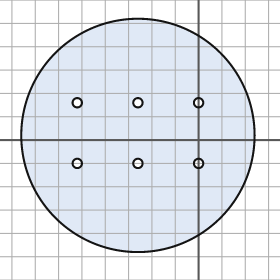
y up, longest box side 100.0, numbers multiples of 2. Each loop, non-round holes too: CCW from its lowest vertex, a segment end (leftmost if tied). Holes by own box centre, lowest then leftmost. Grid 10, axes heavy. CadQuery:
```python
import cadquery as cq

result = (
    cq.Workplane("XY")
    .moveTo(-26.0, 2.0)
    .circle(50.0)
    .moveTo(-52.0, -10.0)
    .circle(2.0)
    .moveTo(-26.0, -10.0)
    .circle(2.0)
    .moveTo(0.0, -10.0)
    .circle(2.0)
    .moveTo(-52.0, 16.0)
    .circle(2.0)
    .moveTo(-26.0, 16.0)
    .circle(2.0)
    .moveTo(0.0, 16.0)
    .circle(2.0)
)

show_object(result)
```